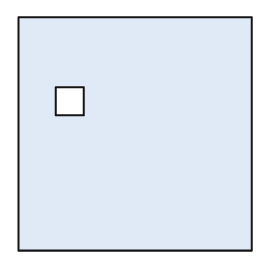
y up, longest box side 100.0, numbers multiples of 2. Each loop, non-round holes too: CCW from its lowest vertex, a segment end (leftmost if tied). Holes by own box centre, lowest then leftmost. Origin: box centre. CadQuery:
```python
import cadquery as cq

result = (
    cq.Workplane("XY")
    .moveTo(-50.0, -50.0)
    .lineTo(50.0, -50.0)
    .lineTo(50.0, 50.0)
    .lineTo(-50.0, 50.0)
    .close()
    .moveTo(-34.0, 8.0)
    .lineTo(-22.0, 8.0)
    .lineTo(-22.0, 20.0)
    .lineTo(-34.0, 20.0)
    .close()
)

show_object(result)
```